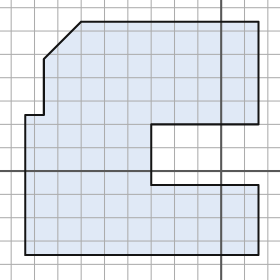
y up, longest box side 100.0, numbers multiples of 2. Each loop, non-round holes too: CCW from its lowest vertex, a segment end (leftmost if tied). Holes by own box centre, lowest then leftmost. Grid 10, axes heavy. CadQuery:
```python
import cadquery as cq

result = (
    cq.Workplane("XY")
    .moveTo(-84.0, -36.0)
    .lineTo(16.0, -36.0)
    .lineTo(16.0, -6.0)
    .lineTo(-30.0, -6.0)
    .lineTo(-30.0, 20.0)
    .lineTo(16.0, 20.0)
    .lineTo(16.0, 64.0)
    .lineTo(-60.0, 64.0)
    .lineTo(-76.0, 48.0)
    .lineTo(-76.0, 24.0)
    .lineTo(-84.0, 24.0)
    .close()
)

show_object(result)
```